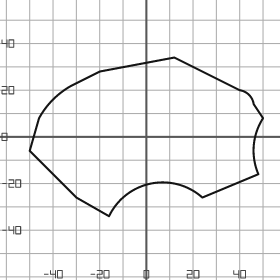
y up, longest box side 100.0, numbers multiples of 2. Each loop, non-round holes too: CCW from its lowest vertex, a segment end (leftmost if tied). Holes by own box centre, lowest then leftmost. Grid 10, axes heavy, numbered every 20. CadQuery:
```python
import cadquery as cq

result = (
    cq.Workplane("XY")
    .moveTo(-16.0, -34.0)
    .threePointArc((2.0, -20.0), (24.0, -26.0))
    .lineTo(48.0, -16.0)
    .threePointArc((46.0, -4.0), (50.0, 8.0))
    .lineTo(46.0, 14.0)
    .threePointArc((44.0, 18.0), (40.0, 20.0))
    .lineTo(12.0, 34.0)
    .lineTo(-20.0, 28.0)
    .lineTo(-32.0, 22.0)
    .threePointArc((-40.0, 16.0), (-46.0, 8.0))
    .lineTo(-50.0, -6.0)
    .lineTo(-30.0, -26.0)
    .close()
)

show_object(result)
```